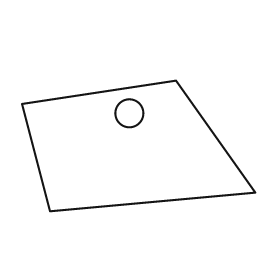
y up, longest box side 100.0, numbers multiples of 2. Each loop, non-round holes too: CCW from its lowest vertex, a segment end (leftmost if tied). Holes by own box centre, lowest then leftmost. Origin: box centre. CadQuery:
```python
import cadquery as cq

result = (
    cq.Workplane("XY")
    .moveTo(-38.0, -28.0)
    .lineTo(50.0, -20.0)
    .lineTo(16.0, 28.0)
    .lineTo(-50.0, 18.0)
    .close()
    .moveTo(-4.0, 14.0)
    .circle(6.0)
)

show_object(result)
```